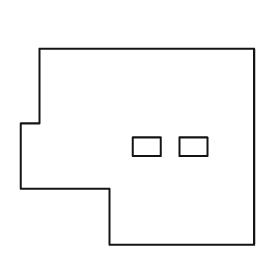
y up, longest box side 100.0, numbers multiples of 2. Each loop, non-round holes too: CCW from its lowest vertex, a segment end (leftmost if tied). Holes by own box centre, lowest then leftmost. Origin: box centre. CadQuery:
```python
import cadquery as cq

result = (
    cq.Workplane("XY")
    .moveTo(-12.0, -42.0)
    .lineTo(50.0, -42.0)
    .lineTo(50.0, 42.0)
    .lineTo(-42.0, 42.0)
    .lineTo(-42.0, 10.0)
    .lineTo(-50.0, 10.0)
    .lineTo(-50.0, -18.0)
    .lineTo(-12.0, -18.0)
    .close()
    .moveTo(-2.0, -4.0)
    .lineTo(10.0, -4.0)
    .lineTo(10.0, 4.0)
    .lineTo(-2.0, 4.0)
    .close()
    .moveTo(18.0, -4.0)
    .lineTo(30.0, -4.0)
    .lineTo(30.0, 4.0)
    .lineTo(18.0, 4.0)
    .close()
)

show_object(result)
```